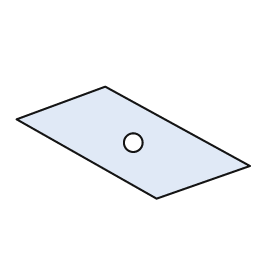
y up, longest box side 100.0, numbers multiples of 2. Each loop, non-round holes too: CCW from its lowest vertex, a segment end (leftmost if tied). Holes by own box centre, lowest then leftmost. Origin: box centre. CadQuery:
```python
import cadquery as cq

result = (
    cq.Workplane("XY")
    .moveTo(10.0, -24.0)
    .lineTo(50.0, -10.0)
    .lineTo(-12.0, 24.0)
    .lineTo(-50.0, 10.0)
    .close()
    .moveTo(0.0, 0.0)
    .circle(4.0)
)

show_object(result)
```